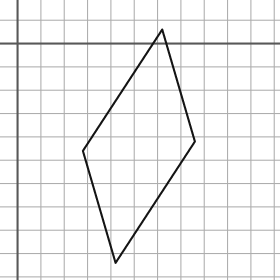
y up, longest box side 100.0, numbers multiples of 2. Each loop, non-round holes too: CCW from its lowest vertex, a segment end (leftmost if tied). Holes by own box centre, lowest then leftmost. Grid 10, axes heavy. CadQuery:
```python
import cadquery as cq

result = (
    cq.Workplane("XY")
    .moveTo(42.0, -94.0)
    .lineTo(76.0, -42.0)
    .lineTo(62.0, 6.0)
    .lineTo(28.0, -46.0)
    .close()
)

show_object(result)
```